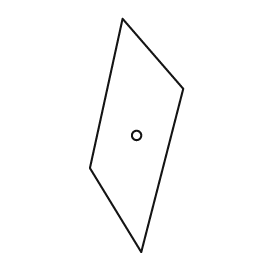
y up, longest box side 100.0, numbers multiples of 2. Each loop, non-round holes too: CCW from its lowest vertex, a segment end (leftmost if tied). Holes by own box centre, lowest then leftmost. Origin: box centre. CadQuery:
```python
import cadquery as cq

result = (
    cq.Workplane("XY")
    .moveTo(2.0, -50.0)
    .lineTo(20.0, 20.0)
    .lineTo(-6.0, 50.0)
    .lineTo(-20.0, -14.0)
    .close()
    .moveTo(0.0, 0.0)
    .circle(2.0)
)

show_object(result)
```